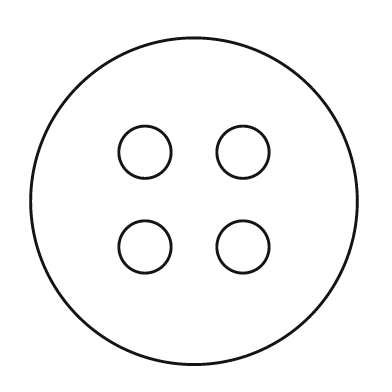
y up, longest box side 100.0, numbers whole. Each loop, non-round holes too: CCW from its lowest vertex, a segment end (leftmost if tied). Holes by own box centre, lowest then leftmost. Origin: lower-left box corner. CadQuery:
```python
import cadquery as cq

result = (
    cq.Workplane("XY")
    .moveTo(50.0, 50.0)
    .circle(50.0)
    .moveTo(35.0, 36.0)
    .circle(8.0)
    .moveTo(65.0, 36.0)
    .circle(8.0)
    .moveTo(35.0, 65.0)
    .circle(8.0)
    .moveTo(65.0, 65.0)
    .circle(8.0)
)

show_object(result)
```